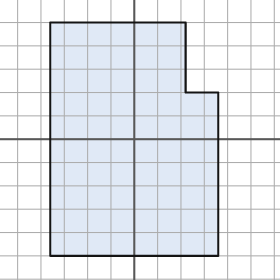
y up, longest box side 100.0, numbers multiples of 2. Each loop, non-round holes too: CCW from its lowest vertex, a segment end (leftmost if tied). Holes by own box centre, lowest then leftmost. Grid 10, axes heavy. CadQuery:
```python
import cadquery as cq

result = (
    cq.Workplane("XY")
    .moveTo(-36.0, -50.0)
    .lineTo(36.0, -50.0)
    .lineTo(36.0, 20.0)
    .lineTo(22.0, 20.0)
    .lineTo(22.0, 50.0)
    .lineTo(-36.0, 50.0)
    .close()
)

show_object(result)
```